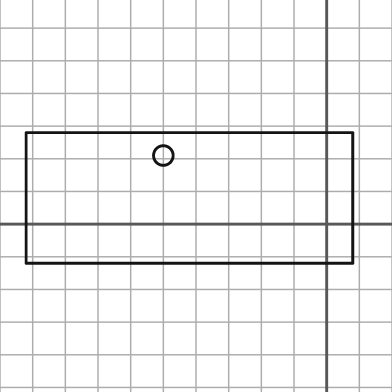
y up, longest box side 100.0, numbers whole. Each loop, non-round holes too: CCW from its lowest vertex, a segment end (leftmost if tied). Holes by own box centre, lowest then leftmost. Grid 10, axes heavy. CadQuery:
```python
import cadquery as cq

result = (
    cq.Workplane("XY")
    .moveTo(-92.0, -12.0)
    .lineTo(8.0, -12.0)
    .lineTo(8.0, 28.0)
    .lineTo(-92.0, 28.0)
    .close()
    .moveTo(-50.0, 21.0)
    .circle(3.0)
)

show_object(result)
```